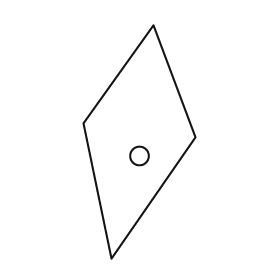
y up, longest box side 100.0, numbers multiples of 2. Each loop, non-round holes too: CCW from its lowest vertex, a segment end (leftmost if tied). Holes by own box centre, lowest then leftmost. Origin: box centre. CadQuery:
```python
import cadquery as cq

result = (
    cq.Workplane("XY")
    .moveTo(-12.0, -50.0)
    .lineTo(24.0, 2.0)
    .lineTo(6.0, 50.0)
    .lineTo(-24.0, 8.0)
    .close()
    .moveTo(0.0, -6.0)
    .circle(4.0)
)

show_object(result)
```